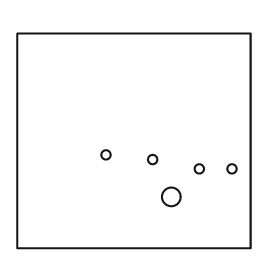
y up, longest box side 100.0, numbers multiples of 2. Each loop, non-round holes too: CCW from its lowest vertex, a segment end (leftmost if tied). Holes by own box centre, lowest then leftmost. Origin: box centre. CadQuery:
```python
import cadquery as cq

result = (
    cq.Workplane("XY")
    .moveTo(-50.0, -46.0)
    .lineTo(50.0, -46.0)
    .lineTo(50.0, 46.0)
    .lineTo(-50.0, 46.0)
    .close()
    .moveTo(16.0, -24.0)
    .circle(4.0)
    .moveTo(28.0, -12.0)
    .circle(2.0)
    .moveTo(42.0, -12.0)
    .circle(2.0)
    .moveTo(8.0, -8.0)
    .circle(2.0)
    .moveTo(-12.0, -6.0)
    .circle(2.0)
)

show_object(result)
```